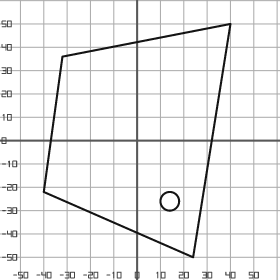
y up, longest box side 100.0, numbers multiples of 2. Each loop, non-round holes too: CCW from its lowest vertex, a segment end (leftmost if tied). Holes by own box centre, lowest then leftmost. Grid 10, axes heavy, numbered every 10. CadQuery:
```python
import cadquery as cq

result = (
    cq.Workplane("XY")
    .moveTo(24.0, -50.0)
    .lineTo(40.0, 50.0)
    .lineTo(-32.0, 36.0)
    .lineTo(-40.0, -22.0)
    .close()
    .moveTo(14.0, -26.0)
    .circle(4.0)
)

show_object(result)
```